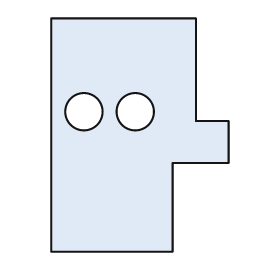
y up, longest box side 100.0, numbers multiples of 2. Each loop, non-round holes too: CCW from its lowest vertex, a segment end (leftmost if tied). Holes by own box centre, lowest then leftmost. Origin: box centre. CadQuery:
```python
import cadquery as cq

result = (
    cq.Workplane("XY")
    .moveTo(-38.0, -50.0)
    .lineTo(14.0, -50.0)
    .lineTo(14.0, -12.0)
    .lineTo(38.0, -12.0)
    .lineTo(38.0, 6.0)
    .lineTo(24.0, 6.0)
    .lineTo(24.0, 50.0)
    .lineTo(-38.0, 50.0)
    .close()
    .moveTo(-24.0, 10.0)
    .circle(8.0)
    .moveTo(-2.0, 10.0)
    .circle(8.0)
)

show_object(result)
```